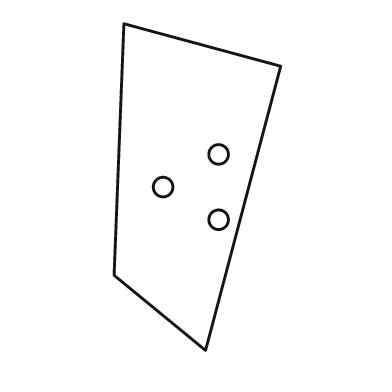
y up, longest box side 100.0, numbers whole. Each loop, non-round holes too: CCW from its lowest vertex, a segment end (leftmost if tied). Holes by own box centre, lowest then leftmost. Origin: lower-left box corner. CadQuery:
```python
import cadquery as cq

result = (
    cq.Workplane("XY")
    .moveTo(28.0, 0.0)
    .lineTo(51.0, 87.0)
    .lineTo(3.0, 100.0)
    .lineTo(0.0, 23.0)
    .close()
    .moveTo(32.0, 40.0)
    .circle(3.0)
    .moveTo(15.0, 50.0)
    .circle(3.0)
    .moveTo(32.0, 60.0)
    .circle(3.0)
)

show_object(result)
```